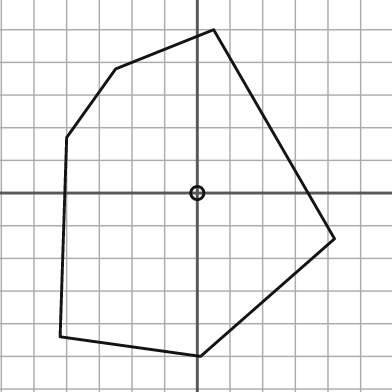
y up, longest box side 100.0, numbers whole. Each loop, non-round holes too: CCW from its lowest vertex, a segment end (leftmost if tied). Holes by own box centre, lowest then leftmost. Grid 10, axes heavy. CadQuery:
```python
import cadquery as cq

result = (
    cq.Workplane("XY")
    .moveTo(1.0, -50.0)
    .lineTo(42.0, -14.0)
    .lineTo(5.0, 50.0)
    .lineTo(-25.0, 38.0)
    .lineTo(-40.0, 17.0)
    .lineTo(-42.0, -44.0)
    .close()
    .moveTo(0.0, 0.0)
    .circle(2.0)
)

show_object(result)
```